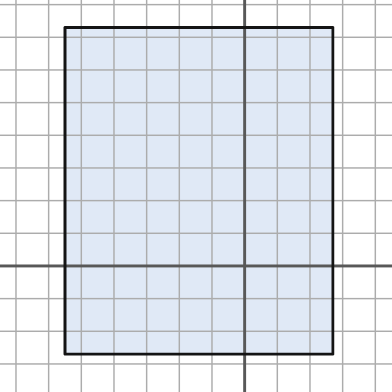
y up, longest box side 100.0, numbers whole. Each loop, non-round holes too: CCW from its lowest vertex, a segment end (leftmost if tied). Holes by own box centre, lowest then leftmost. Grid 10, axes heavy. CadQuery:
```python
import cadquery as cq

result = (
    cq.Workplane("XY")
    .moveTo(-55.0, -27.0)
    .lineTo(27.0, -27.0)
    .lineTo(27.0, 73.0)
    .lineTo(-55.0, 73.0)
    .close()
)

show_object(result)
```